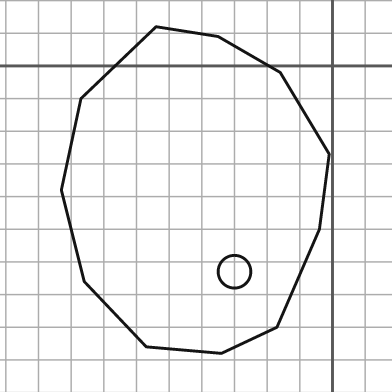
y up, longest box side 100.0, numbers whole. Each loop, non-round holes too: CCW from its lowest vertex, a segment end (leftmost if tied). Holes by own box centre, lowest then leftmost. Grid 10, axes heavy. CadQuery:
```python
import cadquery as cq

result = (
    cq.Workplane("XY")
    .moveTo(-34.0, -88.0)
    .lineTo(-17.0, -80.0)
    .lineTo(-4.0, -50.0)
    .lineTo(-1.0, -27.0)
    .lineTo(-16.0, -2.0)
    .lineTo(-35.0, 9.0)
    .lineTo(-54.0, 12.0)
    .lineTo(-77.0, -10.0)
    .lineTo(-83.0, -38.0)
    .lineTo(-76.0, -66.0)
    .lineTo(-57.0, -86.0)
    .close()
    .moveTo(-30.0, -63.0)
    .circle(5.0)
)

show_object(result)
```